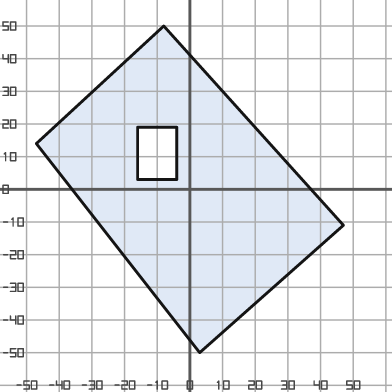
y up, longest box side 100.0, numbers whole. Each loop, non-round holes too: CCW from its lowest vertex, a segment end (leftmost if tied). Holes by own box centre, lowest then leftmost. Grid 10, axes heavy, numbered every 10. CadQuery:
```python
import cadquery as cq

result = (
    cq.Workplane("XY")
    .moveTo(3.0, -50.0)
    .lineTo(47.0, -11.0)
    .lineTo(-8.0, 50.0)
    .lineTo(-47.0, 14.0)
    .close()
    .moveTo(-16.0, 3.0)
    .lineTo(-4.0, 3.0)
    .lineTo(-4.0, 19.0)
    .lineTo(-16.0, 19.0)
    .close()
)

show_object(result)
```